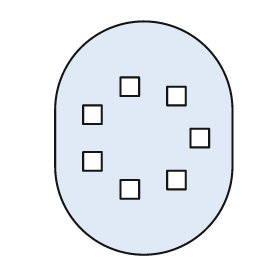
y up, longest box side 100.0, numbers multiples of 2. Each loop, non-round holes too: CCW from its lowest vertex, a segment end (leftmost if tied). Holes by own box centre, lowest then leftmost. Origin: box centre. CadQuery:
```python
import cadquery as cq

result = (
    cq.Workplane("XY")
    .moveTo(-38.0, -12.0)
    .threePointArc((0.0, -50.0), (38.0, -12.0))
    .lineTo(38.0, 12.0)
    .threePointArc((0.0, 50.0), (-38.0, 12.0))
    .close()
    .moveTo(-10.0, -26.0)
    .lineTo(-2.0, -26.0)
    .lineTo(-2.0, -18.0)
    .lineTo(-10.0, -18.0)
    .close()
    .moveTo(10.0, -22.0)
    .lineTo(18.0, -22.0)
    .lineTo(18.0, -14.0)
    .lineTo(10.0, -14.0)
    .close()
    .moveTo(-26.0, -14.0)
    .lineTo(-18.0, -14.0)
    .lineTo(-18.0, -6.0)
    .lineTo(-26.0, -6.0)
    .close()
    .moveTo(20.0, -4.0)
    .lineTo(28.0, -4.0)
    .lineTo(28.0, 4.0)
    .lineTo(20.0, 4.0)
    .close()
    .moveTo(-26.0, 6.0)
    .lineTo(-18.0, 6.0)
    .lineTo(-18.0, 14.0)
    .lineTo(-26.0, 14.0)
    .close()
    .moveTo(10.0, 14.0)
    .lineTo(18.0, 14.0)
    .lineTo(18.0, 22.0)
    .lineTo(10.0, 22.0)
    .close()
    .moveTo(-10.0, 18.0)
    .lineTo(-2.0, 18.0)
    .lineTo(-2.0, 26.0)
    .lineTo(-10.0, 26.0)
    .close()
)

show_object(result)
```